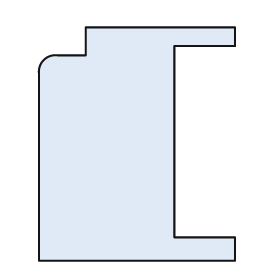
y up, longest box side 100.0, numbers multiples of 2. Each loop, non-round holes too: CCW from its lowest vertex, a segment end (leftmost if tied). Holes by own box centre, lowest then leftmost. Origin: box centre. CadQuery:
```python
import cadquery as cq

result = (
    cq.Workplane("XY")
    .moveTo(-42.0, -50.0)
    .lineTo(42.0, -50.0)
    .lineTo(42.0, -40.0)
    .lineTo(16.0, -40.0)
    .lineTo(16.0, 42.0)
    .lineTo(42.0, 42.0)
    .lineTo(42.0, 50.0)
    .lineTo(-22.0, 50.0)
    .lineTo(-22.0, 38.0)
    .lineTo(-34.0, 38.0)
    .threePointArc((-40.0, 36.0), (-42.0, 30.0))
    .close()
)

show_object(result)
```